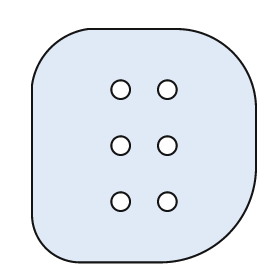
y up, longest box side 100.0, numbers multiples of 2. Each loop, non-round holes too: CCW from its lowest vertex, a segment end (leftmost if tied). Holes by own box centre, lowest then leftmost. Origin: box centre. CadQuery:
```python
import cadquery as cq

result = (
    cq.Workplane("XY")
    .moveTo(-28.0, -50.0)
    .lineTo(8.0, -50.0)
    .threePointArc((36.0, -38.0), (48.0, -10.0))
    .lineTo(48.0, 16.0)
    .threePointArc((38.0, 40.0), (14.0, 50.0))
    .lineTo(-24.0, 50.0)
    .threePointArc((-40.0, 42.0), (-48.0, 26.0))
    .lineTo(-48.0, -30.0)
    .threePointArc((-42.0, -44.0), (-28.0, -50.0))
    .close()
    .moveTo(-10.0, -24.0)
    .circle(4.0)
    .moveTo(10.0, -24.0)
    .circle(4.0)
    .moveTo(-10.0, 0.0)
    .circle(4.0)
    .moveTo(10.0, 0.0)
    .circle(4.0)
    .moveTo(-10.0, 24.0)
    .circle(4.0)
    .moveTo(10.0, 24.0)
    .circle(4.0)
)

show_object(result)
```